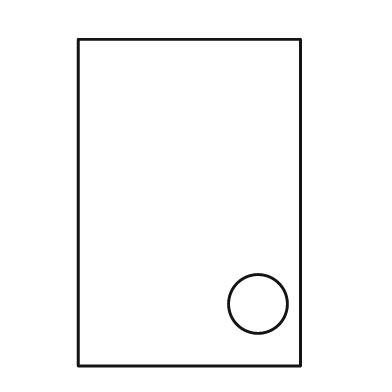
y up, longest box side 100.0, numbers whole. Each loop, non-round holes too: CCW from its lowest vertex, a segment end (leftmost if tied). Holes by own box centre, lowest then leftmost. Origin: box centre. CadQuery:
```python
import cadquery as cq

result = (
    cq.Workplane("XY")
    .moveTo(-34.0, -50.0)
    .lineTo(34.0, -50.0)
    .lineTo(34.0, 50.0)
    .lineTo(-34.0, 50.0)
    .close()
    .moveTo(21.0, -31.0)
    .circle(9.0)
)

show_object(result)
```